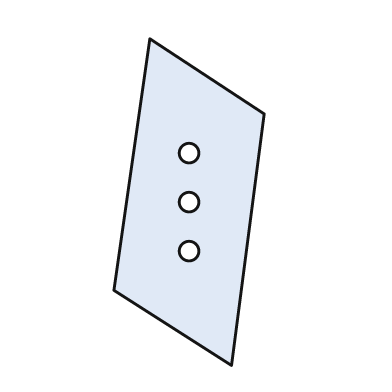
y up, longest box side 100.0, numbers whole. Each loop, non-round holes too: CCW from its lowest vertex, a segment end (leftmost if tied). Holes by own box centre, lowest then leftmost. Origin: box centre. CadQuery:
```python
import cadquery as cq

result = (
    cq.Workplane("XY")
    .moveTo(13.0, -50.0)
    .lineTo(23.0, 27.0)
    .lineTo(-12.0, 50.0)
    .lineTo(-23.0, -27.0)
    .close()
    .moveTo(0.0, -15.0)
    .circle(3.0)
    .moveTo(0.0, 0.0)
    .circle(3.0)
    .moveTo(0.0, 15.0)
    .circle(3.0)
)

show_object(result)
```